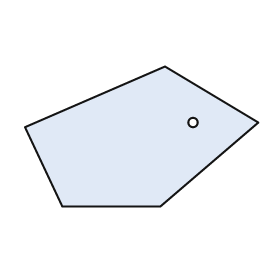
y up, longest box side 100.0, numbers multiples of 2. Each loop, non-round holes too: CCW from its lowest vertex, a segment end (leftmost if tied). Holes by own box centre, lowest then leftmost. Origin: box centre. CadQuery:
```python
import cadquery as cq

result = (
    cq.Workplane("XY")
    .moveTo(-34.0, -30.0)
    .lineTo(8.0, -30.0)
    .lineTo(50.0, 6.0)
    .lineTo(10.0, 30.0)
    .lineTo(-50.0, 4.0)
    .close()
    .moveTo(22.0, 6.0)
    .circle(2.0)
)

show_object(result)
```